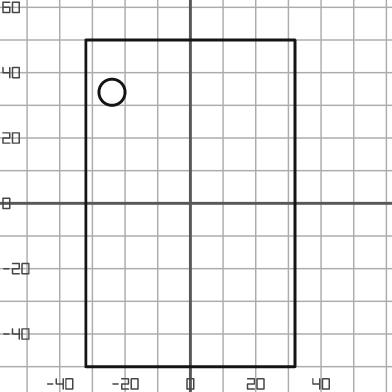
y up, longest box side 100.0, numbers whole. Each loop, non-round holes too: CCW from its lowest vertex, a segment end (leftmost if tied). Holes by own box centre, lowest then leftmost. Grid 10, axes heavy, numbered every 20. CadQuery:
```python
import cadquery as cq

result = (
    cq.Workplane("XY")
    .moveTo(-32.0, -50.0)
    .lineTo(32.0, -50.0)
    .lineTo(32.0, 50.0)
    .lineTo(-32.0, 50.0)
    .close()
    .moveTo(-24.0, 34.0)
    .circle(4.0)
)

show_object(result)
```